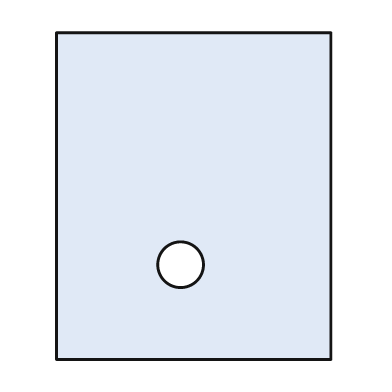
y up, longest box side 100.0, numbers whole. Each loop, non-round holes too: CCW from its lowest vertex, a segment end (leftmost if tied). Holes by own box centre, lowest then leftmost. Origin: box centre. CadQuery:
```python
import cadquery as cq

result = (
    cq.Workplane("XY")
    .moveTo(-42.0, -50.0)
    .lineTo(42.0, -50.0)
    .lineTo(42.0, 50.0)
    .lineTo(-42.0, 50.0)
    .close()
    .moveTo(-4.0, -21.0)
    .circle(7.0)
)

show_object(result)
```